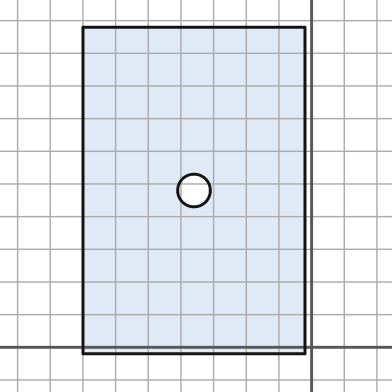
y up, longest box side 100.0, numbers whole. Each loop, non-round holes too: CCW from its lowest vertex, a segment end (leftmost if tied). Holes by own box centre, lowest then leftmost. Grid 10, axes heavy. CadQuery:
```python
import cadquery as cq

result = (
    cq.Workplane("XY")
    .moveTo(-70.0, -2.0)
    .lineTo(-2.0, -2.0)
    .lineTo(-2.0, 98.0)
    .lineTo(-70.0, 98.0)
    .close()
    .moveTo(-36.0, 48.0)
    .circle(5.0)
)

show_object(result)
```